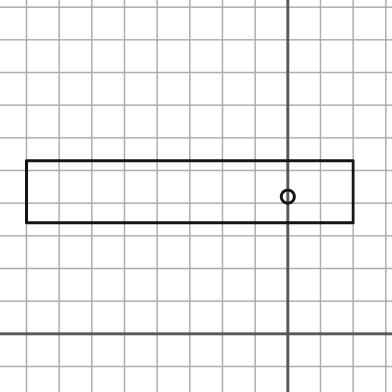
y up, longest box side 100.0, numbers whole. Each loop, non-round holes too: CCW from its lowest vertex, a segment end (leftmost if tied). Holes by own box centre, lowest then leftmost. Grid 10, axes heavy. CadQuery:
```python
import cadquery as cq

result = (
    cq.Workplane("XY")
    .moveTo(-80.0, 34.0)
    .lineTo(20.0, 34.0)
    .lineTo(20.0, 53.0)
    .lineTo(-80.0, 53.0)
    .close()
    .moveTo(0.0, 42.0)
    .circle(2.0)
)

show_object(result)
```